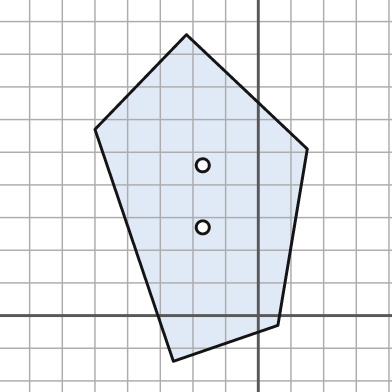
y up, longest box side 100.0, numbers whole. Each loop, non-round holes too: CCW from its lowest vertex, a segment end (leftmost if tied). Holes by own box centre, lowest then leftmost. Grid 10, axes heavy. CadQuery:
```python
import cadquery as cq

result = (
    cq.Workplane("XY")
    .moveTo(-26.0, -14.0)
    .lineTo(6.0, -3.0)
    .lineTo(15.0, 51.0)
    .lineTo(-22.0, 86.0)
    .lineTo(-50.0, 57.0)
    .close()
    .moveTo(-17.0, 27.0)
    .circle(2.0)
    .moveTo(-17.0, 46.0)
    .circle(2.0)
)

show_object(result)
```